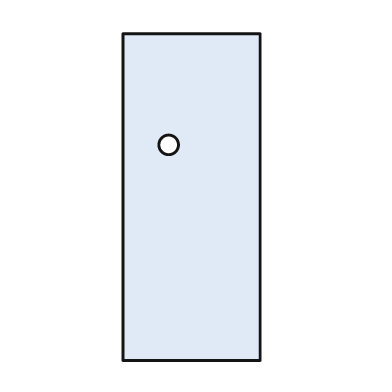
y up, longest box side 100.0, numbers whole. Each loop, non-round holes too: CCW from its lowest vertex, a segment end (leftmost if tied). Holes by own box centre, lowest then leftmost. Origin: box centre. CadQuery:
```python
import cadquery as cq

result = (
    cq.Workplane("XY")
    .moveTo(-21.0, -50.0)
    .lineTo(21.0, -50.0)
    .lineTo(21.0, 50.0)
    .lineTo(-21.0, 50.0)
    .close()
    .moveTo(-7.0, 16.0)
    .circle(3.0)
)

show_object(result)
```